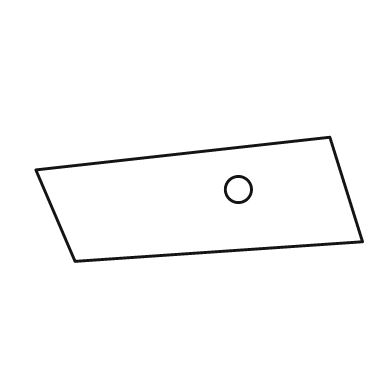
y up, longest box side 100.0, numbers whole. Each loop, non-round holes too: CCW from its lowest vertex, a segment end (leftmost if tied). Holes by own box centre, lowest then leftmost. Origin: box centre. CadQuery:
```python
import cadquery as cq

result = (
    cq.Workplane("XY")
    .moveTo(-38.0, -19.0)
    .lineTo(50.0, -13.0)
    .lineTo(40.0, 19.0)
    .lineTo(-50.0, 9.0)
    .close()
    .moveTo(12.0, 3.0)
    .circle(4.0)
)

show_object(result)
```